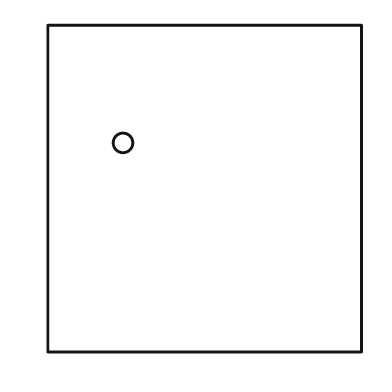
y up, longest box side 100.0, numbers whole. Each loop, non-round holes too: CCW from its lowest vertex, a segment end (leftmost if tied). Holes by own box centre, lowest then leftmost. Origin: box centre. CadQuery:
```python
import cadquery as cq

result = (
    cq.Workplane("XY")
    .moveTo(-48.0, -50.0)
    .lineTo(48.0, -50.0)
    .lineTo(48.0, 50.0)
    .lineTo(-48.0, 50.0)
    .close()
    .moveTo(-25.0, 14.0)
    .circle(3.0)
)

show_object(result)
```